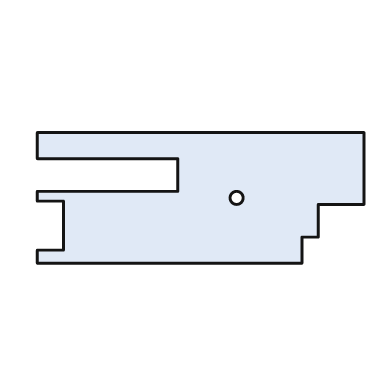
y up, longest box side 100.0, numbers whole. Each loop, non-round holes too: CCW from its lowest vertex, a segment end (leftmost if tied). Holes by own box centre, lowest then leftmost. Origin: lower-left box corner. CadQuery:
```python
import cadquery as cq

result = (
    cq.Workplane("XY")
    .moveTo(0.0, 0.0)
    .lineTo(81.0, 0.0)
    .lineTo(81.0, 8.0)
    .lineTo(86.0, 8.0)
    .lineTo(86.0, 18.0)
    .lineTo(100.0, 18.0)
    .lineTo(100.0, 40.0)
    .lineTo(0.0, 40.0)
    .lineTo(0.0, 32.0)
    .lineTo(43.0, 32.0)
    .lineTo(43.0, 22.0)
    .lineTo(0.0, 22.0)
    .lineTo(0.0, 19.0)
    .lineTo(8.0, 19.0)
    .lineTo(8.0, 4.0)
    .lineTo(0.0, 4.0)
    .close()
    .moveTo(61.0, 20.0)
    .circle(2.0)
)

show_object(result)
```